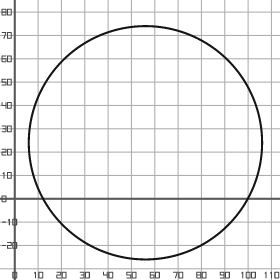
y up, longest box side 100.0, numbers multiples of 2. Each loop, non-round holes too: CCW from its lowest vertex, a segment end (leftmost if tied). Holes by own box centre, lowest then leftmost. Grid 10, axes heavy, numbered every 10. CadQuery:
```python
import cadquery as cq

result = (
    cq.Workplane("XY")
    .moveTo(56.0, 24.0)
    .circle(50.0)
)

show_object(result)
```